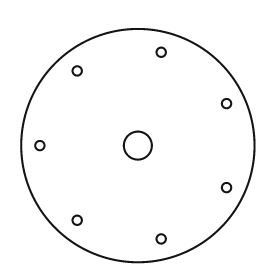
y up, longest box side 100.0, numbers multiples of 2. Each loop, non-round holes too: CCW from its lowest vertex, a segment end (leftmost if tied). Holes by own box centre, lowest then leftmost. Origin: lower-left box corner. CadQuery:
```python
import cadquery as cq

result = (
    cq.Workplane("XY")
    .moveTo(50.0, 50.0)
    .circle(50.0)
    .moveTo(60.0, 10.0)
    .circle(2.0)
    .moveTo(24.0, 18.0)
    .circle(2.0)
    .moveTo(88.0, 32.0)
    .circle(2.0)
    .moveTo(8.0, 50.0)
    .circle(2.0)
    .moveTo(50.0, 50.0)
    .circle(6.0)
    .moveTo(88.0, 68.0)
    .circle(2.0)
    .moveTo(24.0, 82.0)
    .circle(2.0)
    .moveTo(60.0, 90.0)
    .circle(2.0)
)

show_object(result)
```